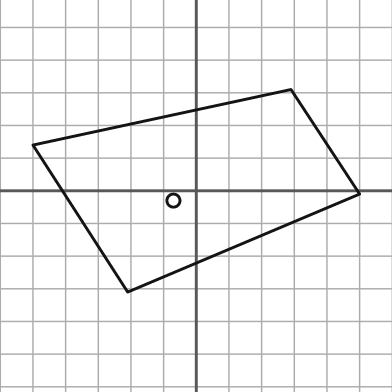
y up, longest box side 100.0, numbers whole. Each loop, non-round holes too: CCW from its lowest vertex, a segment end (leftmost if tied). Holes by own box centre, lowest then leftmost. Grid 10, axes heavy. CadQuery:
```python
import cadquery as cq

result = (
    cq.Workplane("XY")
    .moveTo(-21.0, -31.0)
    .lineTo(50.0, -1.0)
    .lineTo(29.0, 31.0)
    .lineTo(-50.0, 14.0)
    .close()
    .moveTo(-7.0, -3.0)
    .circle(2.0)
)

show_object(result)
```